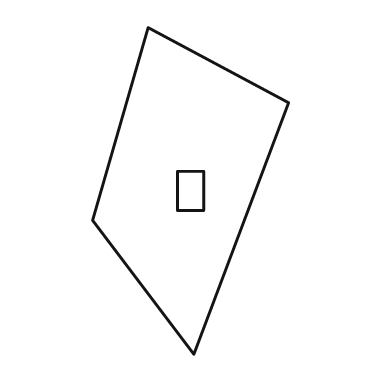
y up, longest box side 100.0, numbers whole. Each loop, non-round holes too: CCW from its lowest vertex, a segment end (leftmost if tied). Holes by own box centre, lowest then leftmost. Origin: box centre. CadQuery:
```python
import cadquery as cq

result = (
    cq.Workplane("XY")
    .moveTo(1.0, -50.0)
    .lineTo(30.0, 27.0)
    .lineTo(-13.0, 50.0)
    .lineTo(-30.0, -9.0)
    .close()
    .moveTo(-4.0, -6.0)
    .lineTo(4.0, -6.0)
    .lineTo(4.0, 6.0)
    .lineTo(-4.0, 6.0)
    .close()
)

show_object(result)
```